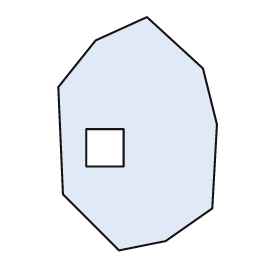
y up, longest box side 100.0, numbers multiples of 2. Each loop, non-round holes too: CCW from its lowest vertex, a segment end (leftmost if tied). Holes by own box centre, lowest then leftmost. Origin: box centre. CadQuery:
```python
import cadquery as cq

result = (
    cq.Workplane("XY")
    .moveTo(-8.0, -50.0)
    .lineTo(12.0, -46.0)
    .lineTo(32.0, -32.0)
    .lineTo(34.0, 4.0)
    .lineTo(28.0, 28.0)
    .lineTo(4.0, 50.0)
    .lineTo(-18.0, 40.0)
    .lineTo(-34.0, 20.0)
    .lineTo(-32.0, -26.0)
    .close()
    .moveTo(-22.0, -14.0)
    .lineTo(-6.0, -14.0)
    .lineTo(-6.0, 2.0)
    .lineTo(-22.0, 2.0)
    .close()
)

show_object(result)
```